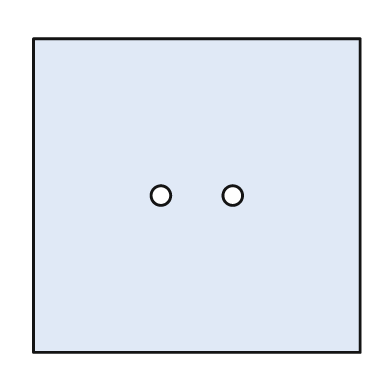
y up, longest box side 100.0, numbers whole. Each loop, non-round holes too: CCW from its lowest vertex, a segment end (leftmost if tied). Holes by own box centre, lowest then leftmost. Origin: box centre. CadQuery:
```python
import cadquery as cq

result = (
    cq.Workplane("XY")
    .moveTo(-50.0, -48.0)
    .lineTo(50.0, -48.0)
    .lineTo(50.0, 48.0)
    .lineTo(-50.0, 48.0)
    .close()
    .moveTo(-11.0, 0.0)
    .circle(3.0)
    .moveTo(11.0, 0.0)
    .circle(3.0)
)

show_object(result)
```